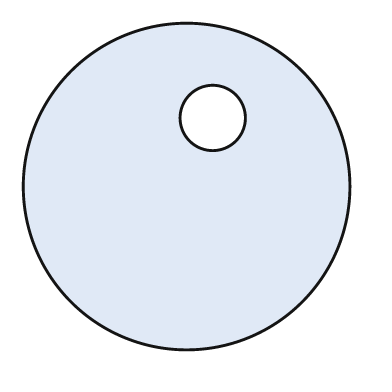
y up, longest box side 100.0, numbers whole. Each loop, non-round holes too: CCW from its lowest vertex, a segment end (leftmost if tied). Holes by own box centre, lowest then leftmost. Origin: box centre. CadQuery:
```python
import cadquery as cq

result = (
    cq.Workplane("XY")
    .moveTo(0.0, 0.0)
    .circle(50.0)
    .moveTo(8.0, 21.0)
    .circle(10.0)
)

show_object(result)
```